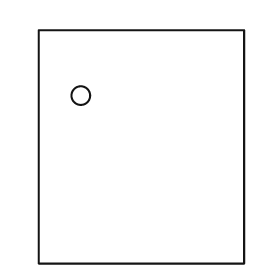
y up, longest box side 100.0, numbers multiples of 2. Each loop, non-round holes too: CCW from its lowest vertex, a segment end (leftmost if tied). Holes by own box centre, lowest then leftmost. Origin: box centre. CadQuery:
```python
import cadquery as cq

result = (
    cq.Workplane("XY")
    .moveTo(-44.0, -50.0)
    .lineTo(44.0, -50.0)
    .lineTo(44.0, 50.0)
    .lineTo(-44.0, 50.0)
    .close()
    .moveTo(-26.0, 22.0)
    .circle(4.0)
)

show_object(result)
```